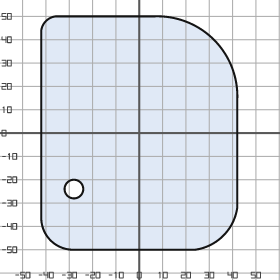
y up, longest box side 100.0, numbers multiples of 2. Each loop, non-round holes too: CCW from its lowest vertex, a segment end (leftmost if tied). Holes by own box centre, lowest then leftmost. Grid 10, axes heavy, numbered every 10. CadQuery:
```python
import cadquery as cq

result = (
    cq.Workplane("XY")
    .moveTo(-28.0, -50.0)
    .lineTo(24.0, -50.0)
    .threePointArc((36.0, -44.0), (42.0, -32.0))
    .lineTo(42.0, 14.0)
    .threePointArc((32.0, 40.0), (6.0, 50.0))
    .lineTo(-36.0, 50.0)
    .threePointArc((-40.0, 48.0), (-42.0, 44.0))
    .lineTo(-42.0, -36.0)
    .threePointArc((-38.0, -46.0), (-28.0, -50.0))
    .close()
    .moveTo(-28.0, -24.0)
    .circle(4.0)
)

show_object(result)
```